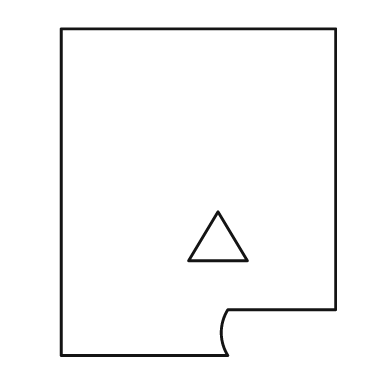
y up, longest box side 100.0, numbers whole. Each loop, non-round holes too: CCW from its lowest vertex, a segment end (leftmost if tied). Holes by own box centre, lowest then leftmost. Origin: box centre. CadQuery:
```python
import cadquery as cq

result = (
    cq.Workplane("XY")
    .moveTo(-42.0, -50.0)
    .lineTo(9.0, -50.0)
    .threePointArc((7.0, -43.0), (9.0, -36.0))
    .lineTo(42.0, -36.0)
    .lineTo(42.0, 50.0)
    .lineTo(-42.0, 50.0)
    .close()
    .moveTo(-3.0, -21.0)
    .lineTo(15.0, -21.0)
    .lineTo(6.0, -6.0)
    .close()
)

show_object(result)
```